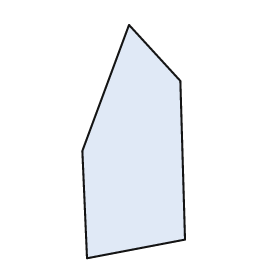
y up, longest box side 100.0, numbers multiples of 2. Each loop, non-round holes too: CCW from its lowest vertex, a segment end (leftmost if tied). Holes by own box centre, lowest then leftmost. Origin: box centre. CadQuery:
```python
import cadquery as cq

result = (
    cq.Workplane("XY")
    .moveTo(-20.0, -50.0)
    .lineTo(22.0, -42.0)
    .lineTo(20.0, 26.0)
    .lineTo(-2.0, 50.0)
    .lineTo(-22.0, -4.0)
    .close()
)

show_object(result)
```